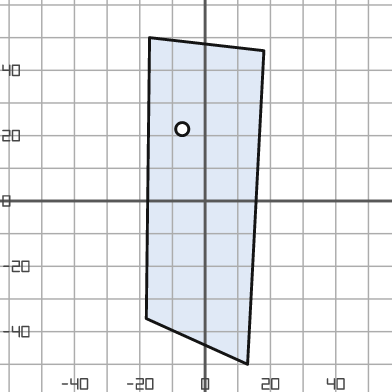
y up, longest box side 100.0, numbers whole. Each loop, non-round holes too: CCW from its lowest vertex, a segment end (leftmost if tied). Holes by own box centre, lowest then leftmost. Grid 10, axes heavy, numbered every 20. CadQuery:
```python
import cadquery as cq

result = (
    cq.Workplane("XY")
    .moveTo(13.0, -50.0)
    .lineTo(18.0, 46.0)
    .lineTo(-17.0, 50.0)
    .lineTo(-18.0, -36.0)
    .close()
    .moveTo(-7.0, 22.0)
    .circle(2.0)
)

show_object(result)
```